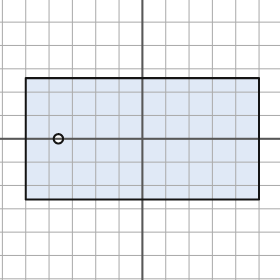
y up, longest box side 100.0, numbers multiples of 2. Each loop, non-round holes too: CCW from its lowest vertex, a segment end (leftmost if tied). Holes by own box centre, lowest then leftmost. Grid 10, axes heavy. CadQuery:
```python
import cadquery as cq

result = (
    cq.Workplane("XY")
    .moveTo(-50.0, -26.0)
    .lineTo(50.0, -26.0)
    .lineTo(50.0, 26.0)
    .lineTo(-50.0, 26.0)
    .close()
    .moveTo(-36.0, 0.0)
    .circle(2.0)
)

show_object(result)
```